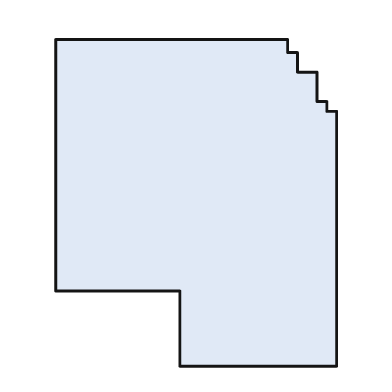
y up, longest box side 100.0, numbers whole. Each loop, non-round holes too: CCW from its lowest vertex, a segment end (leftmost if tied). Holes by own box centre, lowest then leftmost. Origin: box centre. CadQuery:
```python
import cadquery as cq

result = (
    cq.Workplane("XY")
    .moveTo(-5.0, -50.0)
    .lineTo(43.0, -50.0)
    .lineTo(43.0, 28.0)
    .lineTo(40.0, 28.0)
    .lineTo(40.0, 31.0)
    .lineTo(37.0, 31.0)
    .lineTo(37.0, 40.0)
    .lineTo(31.0, 40.0)
    .lineTo(31.0, 46.0)
    .lineTo(28.0, 46.0)
    .lineTo(28.0, 50.0)
    .lineTo(-43.0, 50.0)
    .lineTo(-43.0, -27.0)
    .lineTo(-5.0, -27.0)
    .close()
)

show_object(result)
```